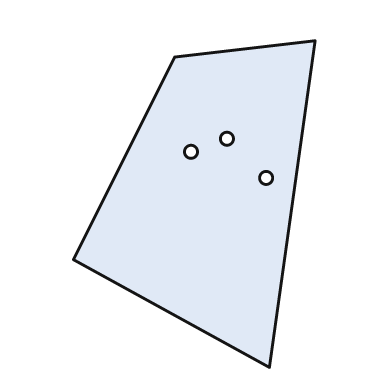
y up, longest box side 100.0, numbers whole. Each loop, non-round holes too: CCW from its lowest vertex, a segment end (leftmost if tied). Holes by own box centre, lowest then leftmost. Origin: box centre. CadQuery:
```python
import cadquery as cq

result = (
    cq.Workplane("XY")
    .moveTo(23.0, -50.0)
    .lineTo(37.0, 50.0)
    .lineTo(-6.0, 45.0)
    .lineTo(-37.0, -17.0)
    .close()
    .moveTo(22.0, 8.0)
    .circle(2.0)
    .moveTo(-1.0, 16.0)
    .circle(2.0)
    .moveTo(10.0, 20.0)
    .circle(2.0)
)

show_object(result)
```